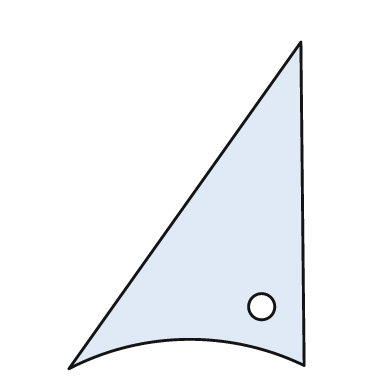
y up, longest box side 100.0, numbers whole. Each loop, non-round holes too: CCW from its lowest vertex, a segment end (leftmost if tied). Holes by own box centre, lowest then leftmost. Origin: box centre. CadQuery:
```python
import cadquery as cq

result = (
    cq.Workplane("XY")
    .moveTo(-36.0, -50.0)
    .threePointArc((0.0, -41.0), (36.0, -49.0))
    .lineTo(35.0, 50.0)
    .close()
    .moveTo(23.0, -31.0)
    .circle(4.0)
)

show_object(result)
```